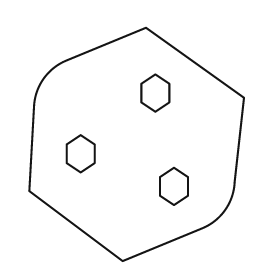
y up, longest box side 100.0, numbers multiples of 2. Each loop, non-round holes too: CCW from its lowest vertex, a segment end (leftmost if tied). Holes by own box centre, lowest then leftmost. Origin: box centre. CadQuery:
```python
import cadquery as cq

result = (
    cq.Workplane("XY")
    .moveTo(-6.0, -50.0)
    .lineTo(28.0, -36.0)
    .threePointArc((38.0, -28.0), (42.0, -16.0))
    .lineTo(46.0, 20.0)
    .lineTo(4.0, 50.0)
    .lineTo(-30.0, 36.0)
    .threePointArc((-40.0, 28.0), (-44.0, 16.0))
    .lineTo(-46.0, -20.0)
    .close()
    .moveTo(16.0, -26.0)
    .lineTo(22.0, -22.0)
    .lineTo(22.0, -14.0)
    .lineTo(16.0, -10.0)
    .lineTo(10.0, -14.0)
    .lineTo(10.0, -22.0)
    .close()
    .moveTo(-24.0, -12.0)
    .lineTo(-18.0, -8.0)
    .lineTo(-18.0, 0.0)
    .lineTo(-24.0, 4.0)
    .lineTo(-30.0, 0.0)
    .lineTo(-30.0, -8.0)
    .close()
    .moveTo(8.0, 14.0)
    .lineTo(14.0, 18.0)
    .lineTo(14.0, 26.0)
    .lineTo(8.0, 30.0)
    .lineTo(2.0, 26.0)
    .lineTo(2.0, 18.0)
    .close()
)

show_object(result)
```